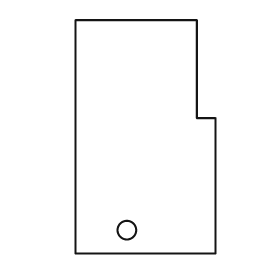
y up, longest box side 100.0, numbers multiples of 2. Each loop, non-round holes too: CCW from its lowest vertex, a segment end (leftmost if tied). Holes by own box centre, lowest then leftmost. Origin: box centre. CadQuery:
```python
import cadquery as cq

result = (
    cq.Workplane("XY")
    .moveTo(-30.0, -50.0)
    .lineTo(30.0, -50.0)
    .lineTo(30.0, 8.0)
    .lineTo(22.0, 8.0)
    .lineTo(22.0, 50.0)
    .lineTo(-30.0, 50.0)
    .close()
    .moveTo(-8.0, -40.0)
    .circle(4.0)
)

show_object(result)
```